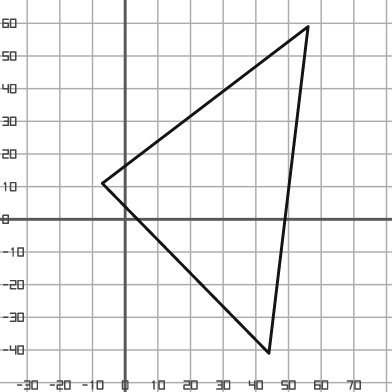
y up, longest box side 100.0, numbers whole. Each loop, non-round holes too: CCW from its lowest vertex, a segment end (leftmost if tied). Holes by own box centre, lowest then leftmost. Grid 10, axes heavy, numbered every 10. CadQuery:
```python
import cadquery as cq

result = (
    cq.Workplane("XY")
    .moveTo(44.0, -41.0)
    .lineTo(56.0, 59.0)
    .lineTo(-7.0, 11.0)
    .close()
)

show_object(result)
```